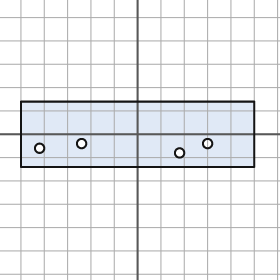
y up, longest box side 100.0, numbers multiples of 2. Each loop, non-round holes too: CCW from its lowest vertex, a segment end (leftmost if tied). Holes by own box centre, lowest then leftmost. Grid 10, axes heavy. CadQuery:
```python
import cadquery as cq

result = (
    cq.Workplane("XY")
    .moveTo(-50.0, -14.0)
    .lineTo(50.0, -14.0)
    .lineTo(50.0, 14.0)
    .lineTo(-50.0, 14.0)
    .close()
    .moveTo(18.0, -8.0)
    .circle(2.0)
    .moveTo(-42.0, -6.0)
    .circle(2.0)
    .moveTo(-24.0, -4.0)
    .circle(2.0)
    .moveTo(30.0, -4.0)
    .circle(2.0)
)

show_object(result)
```